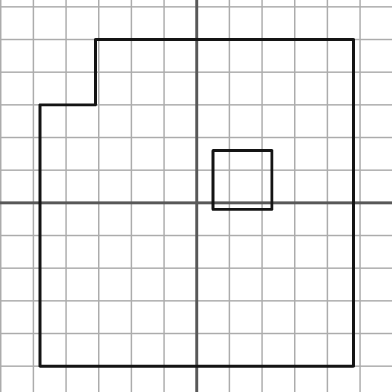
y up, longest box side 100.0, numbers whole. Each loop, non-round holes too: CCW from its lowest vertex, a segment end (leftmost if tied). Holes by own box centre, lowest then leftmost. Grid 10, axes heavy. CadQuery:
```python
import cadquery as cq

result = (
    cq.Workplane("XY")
    .moveTo(-48.0, -50.0)
    .lineTo(48.0, -50.0)
    .lineTo(48.0, 50.0)
    .lineTo(-31.0, 50.0)
    .lineTo(-31.0, 30.0)
    .lineTo(-48.0, 30.0)
    .close()
    .moveTo(5.0, -2.0)
    .lineTo(23.0, -2.0)
    .lineTo(23.0, 16.0)
    .lineTo(5.0, 16.0)
    .close()
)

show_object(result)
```